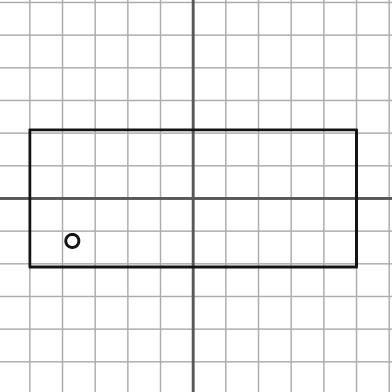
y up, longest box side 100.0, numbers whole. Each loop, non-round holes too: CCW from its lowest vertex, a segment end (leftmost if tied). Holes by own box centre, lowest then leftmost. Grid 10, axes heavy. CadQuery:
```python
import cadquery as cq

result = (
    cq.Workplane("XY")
    .moveTo(-50.0, -21.0)
    .lineTo(50.0, -21.0)
    .lineTo(50.0, 21.0)
    .lineTo(-50.0, 21.0)
    .close()
    .moveTo(-37.0, -13.0)
    .circle(2.0)
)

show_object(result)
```